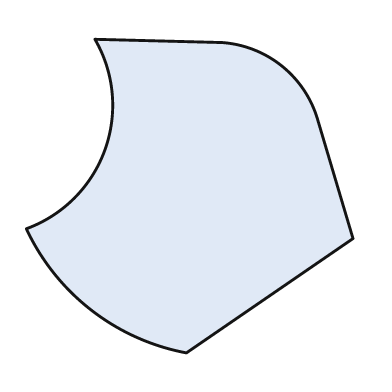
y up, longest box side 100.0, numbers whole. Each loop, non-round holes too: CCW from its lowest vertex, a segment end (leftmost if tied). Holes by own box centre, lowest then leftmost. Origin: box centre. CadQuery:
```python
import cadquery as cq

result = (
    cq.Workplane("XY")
    .moveTo(-1.0, -48.0)
    .lineTo(50.0, -13.0)
    .lineTo(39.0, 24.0)
    .threePointArc((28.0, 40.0), (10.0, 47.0))
    .lineTo(-29.0, 48.0)
    .threePointArc((-26.0, 14.0), (-50.0, -10.0))
    .threePointArc((-30.0, -35.0), (-1.0, -48.0))
    .close()
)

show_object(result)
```